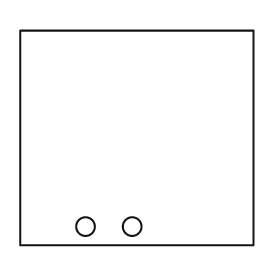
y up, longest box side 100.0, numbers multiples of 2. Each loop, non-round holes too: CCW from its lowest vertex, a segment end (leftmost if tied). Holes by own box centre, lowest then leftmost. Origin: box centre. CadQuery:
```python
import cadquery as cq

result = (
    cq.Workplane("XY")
    .moveTo(-50.0, -46.0)
    .lineTo(50.0, -46.0)
    .lineTo(50.0, 46.0)
    .lineTo(-50.0, 46.0)
    .close()
    .moveTo(-22.0, -38.0)
    .circle(4.0)
    .moveTo(-2.0, -38.0)
    .circle(4.0)
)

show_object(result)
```